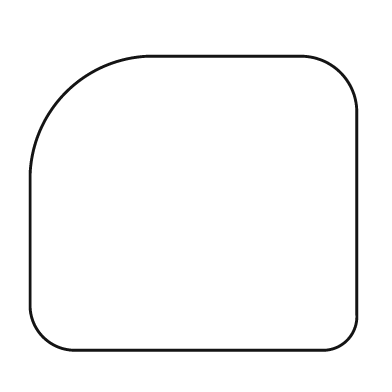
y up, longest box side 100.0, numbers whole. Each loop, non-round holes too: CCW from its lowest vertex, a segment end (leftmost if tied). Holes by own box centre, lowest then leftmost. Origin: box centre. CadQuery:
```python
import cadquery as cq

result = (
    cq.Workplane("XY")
    .moveTo(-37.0, -45.0)
    .lineTo(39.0, -45.0)
    .threePointArc((47.0, -42.0), (50.0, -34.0))
    .lineTo(50.0, 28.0)
    .threePointArc((45.0, 40.0), (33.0, 45.0))
    .lineTo(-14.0, 45.0)
    .threePointArc((-39.0, 34.0), (-50.0, 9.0))
    .lineTo(-50.0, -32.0)
    .threePointArc((-46.0, -41.0), (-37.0, -45.0))
    .close()
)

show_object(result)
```